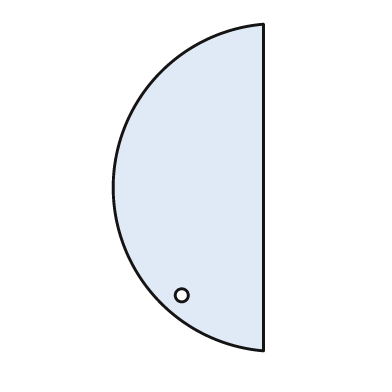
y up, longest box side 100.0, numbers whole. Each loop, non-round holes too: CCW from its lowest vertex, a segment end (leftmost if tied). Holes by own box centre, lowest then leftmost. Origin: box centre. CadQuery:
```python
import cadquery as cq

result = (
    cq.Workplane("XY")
    .moveTo(23.0, -50.0)
    .lineTo(23.0, 50.0)
    .threePointArc((-23.0, 0.0), (23.0, -50.0))
    .close()
    .moveTo(-2.0, -33.0)
    .circle(2.0)
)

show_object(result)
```